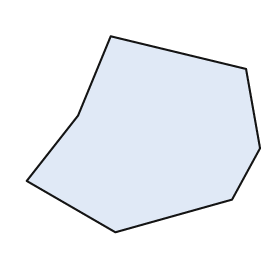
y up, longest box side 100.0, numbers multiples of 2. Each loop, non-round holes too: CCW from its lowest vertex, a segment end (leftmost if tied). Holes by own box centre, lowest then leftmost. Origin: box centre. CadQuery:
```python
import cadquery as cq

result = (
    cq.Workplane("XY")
    .moveTo(-12.0, -42.0)
    .lineTo(38.0, -28.0)
    .lineTo(50.0, -6.0)
    .lineTo(44.0, 28.0)
    .lineTo(-14.0, 42.0)
    .lineTo(-28.0, 8.0)
    .lineTo(-50.0, -20.0)
    .close()
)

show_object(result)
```